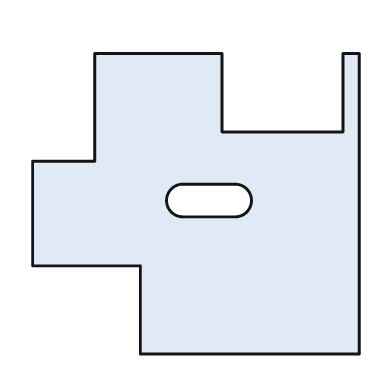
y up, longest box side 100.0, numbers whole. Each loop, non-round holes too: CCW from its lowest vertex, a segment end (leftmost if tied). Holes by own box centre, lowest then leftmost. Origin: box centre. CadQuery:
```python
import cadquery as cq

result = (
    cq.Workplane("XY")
    .moveTo(-17.0, -46.0)
    .lineTo(50.0, -46.0)
    .lineTo(50.0, 46.0)
    .lineTo(45.0, 46.0)
    .lineTo(45.0, 22.0)
    .lineTo(8.0, 22.0)
    .lineTo(8.0, 46.0)
    .lineTo(-31.0, 46.0)
    .lineTo(-31.0, 13.0)
    .lineTo(-50.0, 13.0)
    .lineTo(-50.0, -19.0)
    .lineTo(-17.0, -19.0)
    .close()
    .moveTo(-4.0, -4.0)
    .lineTo(12.0, -4.0)
    .threePointArc((17.0, 1.0), (12.0, 6.0))
    .lineTo(-4.0, 6.0)
    .threePointArc((-9.0, 1.0), (-4.0, -4.0))
    .close()
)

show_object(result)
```